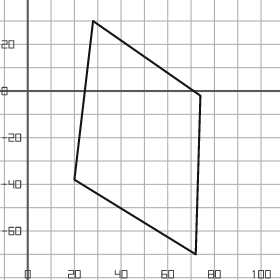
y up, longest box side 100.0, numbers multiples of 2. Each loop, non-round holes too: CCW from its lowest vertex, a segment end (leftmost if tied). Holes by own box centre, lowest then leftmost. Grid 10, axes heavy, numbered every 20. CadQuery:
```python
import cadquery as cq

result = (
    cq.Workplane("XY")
    .moveTo(72.0, -70.0)
    .lineTo(74.0, -2.0)
    .lineTo(28.0, 30.0)
    .lineTo(20.0, -38.0)
    .close()
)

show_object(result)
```